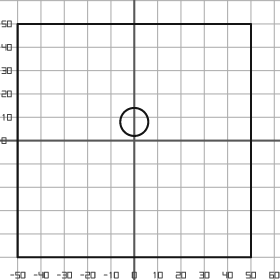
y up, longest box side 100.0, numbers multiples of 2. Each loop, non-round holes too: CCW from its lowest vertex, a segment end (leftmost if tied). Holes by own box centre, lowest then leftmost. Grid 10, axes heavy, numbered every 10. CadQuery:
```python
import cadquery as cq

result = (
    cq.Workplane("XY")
    .moveTo(-50.0, -50.0)
    .lineTo(50.0, -50.0)
    .lineTo(50.0, 50.0)
    .lineTo(-50.0, 50.0)
    .close()
    .moveTo(0.0, 8.0)
    .circle(6.0)
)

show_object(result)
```